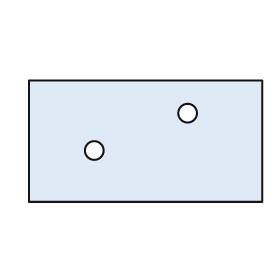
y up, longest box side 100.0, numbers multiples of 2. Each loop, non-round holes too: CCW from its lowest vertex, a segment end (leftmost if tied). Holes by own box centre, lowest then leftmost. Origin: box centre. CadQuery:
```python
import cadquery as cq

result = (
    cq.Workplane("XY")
    .moveTo(-50.0, -26.0)
    .lineTo(50.0, -26.0)
    .lineTo(50.0, 26.0)
    .lineTo(-50.0, 26.0)
    .close()
    .moveTo(-22.0, -4.0)
    .circle(4.0)
    .moveTo(18.0, 12.0)
    .circle(4.0)
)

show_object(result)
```